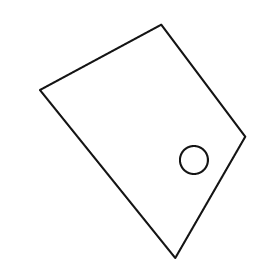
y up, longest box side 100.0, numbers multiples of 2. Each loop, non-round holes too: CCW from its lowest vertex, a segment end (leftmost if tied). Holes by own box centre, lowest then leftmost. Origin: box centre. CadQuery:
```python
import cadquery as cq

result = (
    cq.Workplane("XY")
    .moveTo(14.0, -50.0)
    .lineTo(44.0, 2.0)
    .lineTo(8.0, 50.0)
    .lineTo(-44.0, 22.0)
    .close()
    .moveTo(22.0, -8.0)
    .circle(6.0)
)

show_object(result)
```